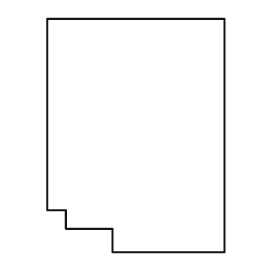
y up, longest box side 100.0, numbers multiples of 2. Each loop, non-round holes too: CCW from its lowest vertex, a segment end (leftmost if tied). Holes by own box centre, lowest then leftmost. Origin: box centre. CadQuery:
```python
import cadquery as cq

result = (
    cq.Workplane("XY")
    .moveTo(-10.0, -50.0)
    .lineTo(38.0, -50.0)
    .lineTo(38.0, 50.0)
    .lineTo(-38.0, 50.0)
    .lineTo(-38.0, -32.0)
    .lineTo(-30.0, -32.0)
    .lineTo(-30.0, -40.0)
    .lineTo(-10.0, -40.0)
    .close()
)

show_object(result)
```